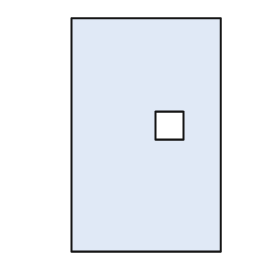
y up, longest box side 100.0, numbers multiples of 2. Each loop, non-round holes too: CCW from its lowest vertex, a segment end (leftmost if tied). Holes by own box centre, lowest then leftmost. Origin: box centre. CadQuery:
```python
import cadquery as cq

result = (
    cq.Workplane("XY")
    .moveTo(-32.0, -50.0)
    .lineTo(32.0, -50.0)
    .lineTo(32.0, 50.0)
    .lineTo(-32.0, 50.0)
    .close()
    .moveTo(4.0, -2.0)
    .lineTo(16.0, -2.0)
    .lineTo(16.0, 10.0)
    .lineTo(4.0, 10.0)
    .close()
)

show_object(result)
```